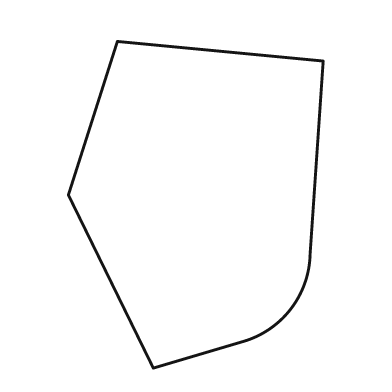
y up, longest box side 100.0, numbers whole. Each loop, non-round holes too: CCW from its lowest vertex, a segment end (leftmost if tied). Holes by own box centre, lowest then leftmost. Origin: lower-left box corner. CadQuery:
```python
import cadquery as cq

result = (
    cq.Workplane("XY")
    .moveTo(26.0, 0.0)
    .lineTo(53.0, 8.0)
    .threePointArc((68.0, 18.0), (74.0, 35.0))
    .lineTo(78.0, 94.0)
    .lineTo(15.0, 100.0)
    .lineTo(0.0, 53.0)
    .close()
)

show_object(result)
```